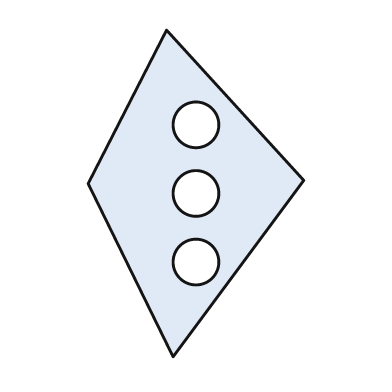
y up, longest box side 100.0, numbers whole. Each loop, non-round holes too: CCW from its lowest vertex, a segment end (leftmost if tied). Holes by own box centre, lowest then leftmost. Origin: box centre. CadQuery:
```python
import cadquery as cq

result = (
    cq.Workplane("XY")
    .moveTo(-7.0, -50.0)
    .lineTo(33.0, 4.0)
    .lineTo(-9.0, 50.0)
    .lineTo(-33.0, 3.0)
    .close()
    .moveTo(0.0, -21.0)
    .circle(7.0)
    .moveTo(0.0, 0.0)
    .circle(7.0)
    .moveTo(0.0, 21.0)
    .circle(7.0)
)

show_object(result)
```